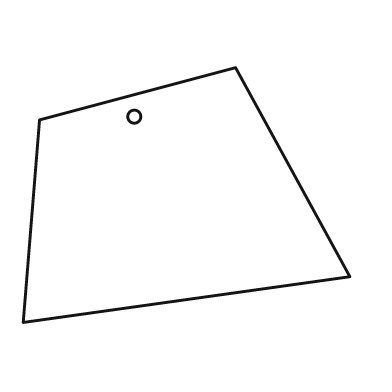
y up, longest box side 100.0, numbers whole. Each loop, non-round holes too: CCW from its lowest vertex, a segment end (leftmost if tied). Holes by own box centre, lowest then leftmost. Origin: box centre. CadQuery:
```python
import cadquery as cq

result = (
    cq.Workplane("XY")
    .moveTo(-50.0, -39.0)
    .lineTo(50.0, -25.0)
    .lineTo(15.0, 39.0)
    .lineTo(-45.0, 23.0)
    .close()
    .moveTo(-16.0, 24.0)
    .circle(2.0)
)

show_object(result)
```